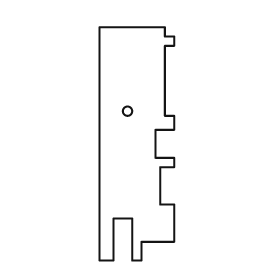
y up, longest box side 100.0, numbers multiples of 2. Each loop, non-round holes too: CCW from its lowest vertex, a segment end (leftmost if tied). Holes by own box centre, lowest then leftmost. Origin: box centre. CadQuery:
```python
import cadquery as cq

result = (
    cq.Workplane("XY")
    .moveTo(-16.0, -50.0)
    .lineTo(-10.0, -50.0)
    .lineTo(-10.0, -32.0)
    .lineTo(-2.0, -32.0)
    .lineTo(-2.0, -50.0)
    .lineTo(2.0, -50.0)
    .lineTo(2.0, -42.0)
    .lineTo(16.0, -42.0)
    .lineTo(16.0, -26.0)
    .lineTo(10.0, -26.0)
    .lineTo(10.0, -10.0)
    .lineTo(16.0, -10.0)
    .lineTo(16.0, -6.0)
    .lineTo(8.0, -6.0)
    .lineTo(8.0, 6.0)
    .lineTo(16.0, 6.0)
    .lineTo(16.0, 12.0)
    .lineTo(12.0, 12.0)
    .lineTo(12.0, 42.0)
    .lineTo(16.0, 42.0)
    .lineTo(16.0, 46.0)
    .lineTo(12.0, 46.0)
    .lineTo(12.0, 50.0)
    .lineTo(-16.0, 50.0)
    .close()
    .moveTo(-4.0, 14.0)
    .circle(2.0)
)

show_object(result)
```